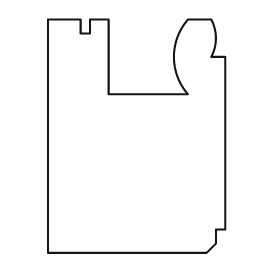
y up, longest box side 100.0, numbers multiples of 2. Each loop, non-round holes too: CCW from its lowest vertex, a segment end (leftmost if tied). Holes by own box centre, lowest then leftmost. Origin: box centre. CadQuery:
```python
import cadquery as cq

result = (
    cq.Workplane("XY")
    .moveTo(-38.0, -50.0)
    .lineTo(30.0, -50.0)
    .lineTo(34.0, -46.0)
    .lineTo(34.0, -40.0)
    .lineTo(38.0, -40.0)
    .lineTo(38.0, 34.0)
    .lineTo(32.0, 34.0)
    .threePointArc((34.0, 42.0), (32.0, 50.0))
    .lineTo(22.0, 50.0)
    .threePointArc((16.0, 34.0), (22.0, 18.0))
    .lineTo(-12.0, 18.0)
    .lineTo(-12.0, 50.0)
    .lineTo(-20.0, 50.0)
    .lineTo(-20.0, 44.0)
    .lineTo(-24.0, 44.0)
    .lineTo(-24.0, 50.0)
    .lineTo(-38.0, 50.0)
    .close()
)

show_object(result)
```